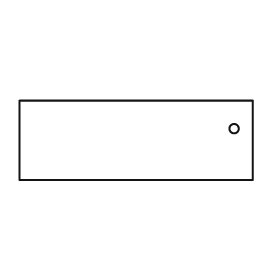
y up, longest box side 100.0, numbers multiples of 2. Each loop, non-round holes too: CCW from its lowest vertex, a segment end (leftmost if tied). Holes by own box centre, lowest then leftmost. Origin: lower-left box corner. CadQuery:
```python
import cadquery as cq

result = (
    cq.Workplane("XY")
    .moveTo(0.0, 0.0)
    .lineTo(100.0, 0.0)
    .lineTo(100.0, 34.0)
    .lineTo(0.0, 34.0)
    .close()
    .moveTo(92.0, 22.0)
    .circle(2.0)
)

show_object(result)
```